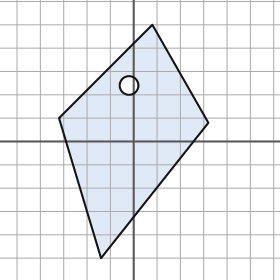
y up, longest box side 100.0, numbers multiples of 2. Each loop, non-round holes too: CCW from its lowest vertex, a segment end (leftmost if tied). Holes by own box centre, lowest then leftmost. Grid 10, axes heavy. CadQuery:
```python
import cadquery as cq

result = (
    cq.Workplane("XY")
    .moveTo(-14.0, -50.0)
    .lineTo(32.0, 8.0)
    .lineTo(8.0, 50.0)
    .lineTo(-32.0, 10.0)
    .close()
    .moveTo(-2.0, 24.0)
    .circle(4.0)
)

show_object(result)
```